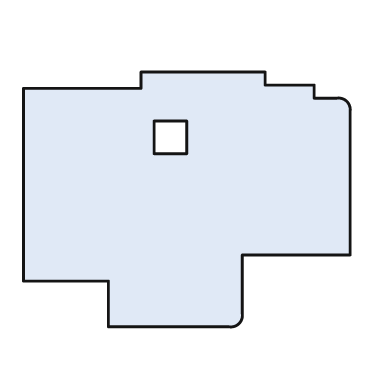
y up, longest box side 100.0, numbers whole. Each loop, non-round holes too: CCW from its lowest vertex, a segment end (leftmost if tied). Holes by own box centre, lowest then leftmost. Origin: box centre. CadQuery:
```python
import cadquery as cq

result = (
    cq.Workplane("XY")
    .moveTo(-24.0, -39.0)
    .lineTo(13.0, -39.0)
    .threePointArc((16.0, -38.0), (17.0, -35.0))
    .lineTo(17.0, -17.0)
    .lineTo(50.0, -17.0)
    .lineTo(50.0, 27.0)
    .threePointArc((49.0, 30.0), (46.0, 31.0))
    .lineTo(39.0, 31.0)
    .lineTo(39.0, 35.0)
    .lineTo(24.0, 35.0)
    .lineTo(24.0, 39.0)
    .lineTo(-14.0, 39.0)
    .lineTo(-14.0, 34.0)
    .lineTo(-50.0, 34.0)
    .lineTo(-50.0, -25.0)
    .lineTo(-24.0, -25.0)
    .close()
    .moveTo(-10.0, 14.0)
    .lineTo(0.0, 14.0)
    .lineTo(0.0, 24.0)
    .lineTo(-10.0, 24.0)
    .close()
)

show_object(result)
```